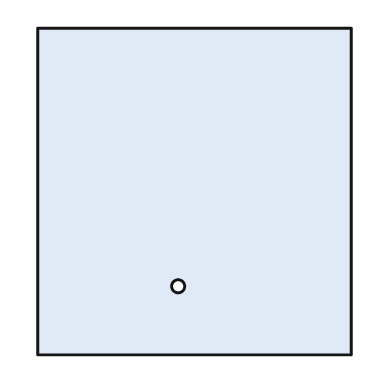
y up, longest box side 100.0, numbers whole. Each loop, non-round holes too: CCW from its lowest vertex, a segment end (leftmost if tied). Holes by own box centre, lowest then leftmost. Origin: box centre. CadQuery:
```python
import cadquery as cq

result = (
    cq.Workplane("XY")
    .moveTo(-48.0, -50.0)
    .lineTo(48.0, -50.0)
    .lineTo(48.0, 50.0)
    .lineTo(-48.0, 50.0)
    .close()
    .moveTo(-5.0, -29.0)
    .circle(2.0)
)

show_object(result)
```